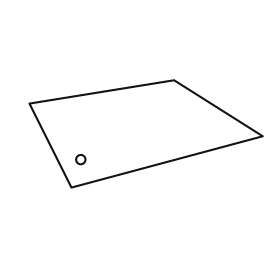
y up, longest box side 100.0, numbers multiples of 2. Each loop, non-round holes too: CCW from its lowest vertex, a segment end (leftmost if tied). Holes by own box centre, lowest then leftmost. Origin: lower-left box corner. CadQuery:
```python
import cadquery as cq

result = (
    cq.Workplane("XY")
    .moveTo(18.0, 0.0)
    .lineTo(100.0, 22.0)
    .lineTo(62.0, 46.0)
    .lineTo(0.0, 36.0)
    .close()
    .moveTo(22.0, 12.0)
    .circle(2.0)
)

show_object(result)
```